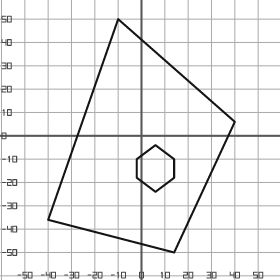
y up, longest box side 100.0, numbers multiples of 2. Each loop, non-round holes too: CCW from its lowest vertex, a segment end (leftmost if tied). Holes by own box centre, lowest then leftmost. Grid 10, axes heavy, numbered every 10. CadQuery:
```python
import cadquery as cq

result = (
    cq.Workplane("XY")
    .moveTo(14.0, -50.0)
    .lineTo(40.0, 6.0)
    .lineTo(-10.0, 50.0)
    .lineTo(-40.0, -36.0)
    .close()
    .moveTo(6.0, -24.0)
    .lineTo(14.0, -18.0)
    .lineTo(14.0, -10.0)
    .lineTo(6.0, -4.0)
    .lineTo(-2.0, -10.0)
    .lineTo(-2.0, -18.0)
    .close()
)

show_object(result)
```